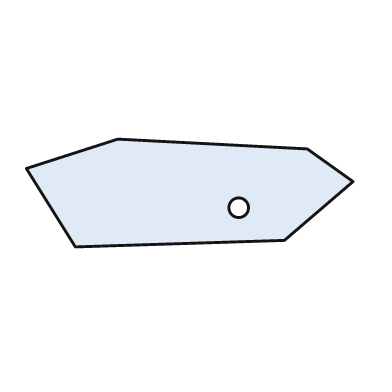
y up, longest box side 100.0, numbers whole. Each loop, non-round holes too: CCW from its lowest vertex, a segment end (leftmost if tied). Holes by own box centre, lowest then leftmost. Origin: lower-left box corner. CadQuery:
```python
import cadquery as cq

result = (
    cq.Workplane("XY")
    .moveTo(15.0, 0.0)
    .lineTo(79.0, 2.0)
    .lineTo(100.0, 20.0)
    .lineTo(86.0, 30.0)
    .lineTo(28.0, 33.0)
    .lineTo(0.0, 24.0)
    .close()
    .moveTo(65.0, 12.0)
    .circle(3.0)
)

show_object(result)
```